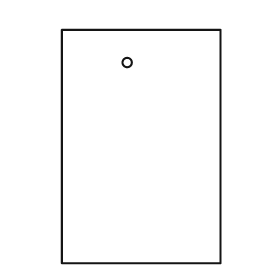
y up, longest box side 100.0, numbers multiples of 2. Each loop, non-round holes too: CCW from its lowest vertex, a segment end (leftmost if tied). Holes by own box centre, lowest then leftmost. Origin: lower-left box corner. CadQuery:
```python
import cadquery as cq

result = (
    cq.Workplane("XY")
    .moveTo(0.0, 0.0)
    .lineTo(68.0, 0.0)
    .lineTo(68.0, 100.0)
    .lineTo(0.0, 100.0)
    .close()
    .moveTo(28.0, 86.0)
    .circle(2.0)
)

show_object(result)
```